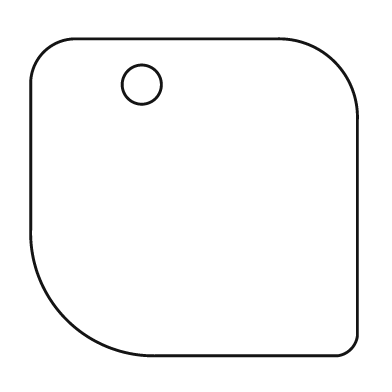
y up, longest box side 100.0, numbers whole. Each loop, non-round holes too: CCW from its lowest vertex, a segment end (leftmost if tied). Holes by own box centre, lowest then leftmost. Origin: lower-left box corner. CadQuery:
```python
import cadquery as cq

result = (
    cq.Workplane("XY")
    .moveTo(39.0, 0.0)
    .lineTo(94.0, 0.0)
    .threePointArc((98.0, 2.0), (100.0, 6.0))
    .lineTo(100.0, 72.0)
    .threePointArc((93.0, 90.0), (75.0, 97.0))
    .lineTo(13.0, 97.0)
    .threePointArc((4.0, 93.0), (0.0, 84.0))
    .lineTo(0.0, 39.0)
    .threePointArc((11.0, 11.0), (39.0, 0.0))
    .close()
    .moveTo(34.0, 83.0)
    .circle(6.0)
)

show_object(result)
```